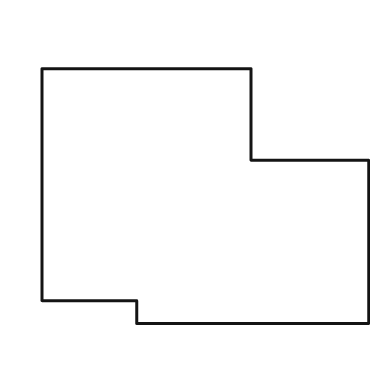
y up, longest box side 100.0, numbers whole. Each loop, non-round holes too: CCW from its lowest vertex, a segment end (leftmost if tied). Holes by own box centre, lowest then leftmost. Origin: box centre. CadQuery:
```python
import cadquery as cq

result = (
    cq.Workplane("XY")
    .moveTo(-21.0, -39.0)
    .lineTo(50.0, -39.0)
    .lineTo(50.0, 11.0)
    .lineTo(14.0, 11.0)
    .lineTo(14.0, 39.0)
    .lineTo(-50.0, 39.0)
    .lineTo(-50.0, -32.0)
    .lineTo(-21.0, -32.0)
    .close()
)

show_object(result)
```